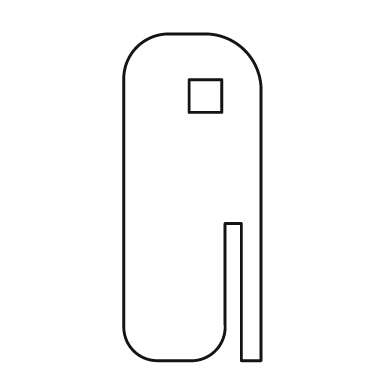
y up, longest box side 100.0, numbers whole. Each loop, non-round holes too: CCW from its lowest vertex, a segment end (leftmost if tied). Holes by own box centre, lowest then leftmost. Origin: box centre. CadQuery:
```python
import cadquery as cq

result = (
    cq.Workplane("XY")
    .moveTo(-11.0, -50.0)
    .lineTo(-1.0, -50.0)
    .threePointArc((7.0, -47.0), (10.0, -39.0))
    .lineTo(10.0, -8.0)
    .lineTo(15.0, -8.0)
    .lineTo(15.0, -50.0)
    .lineTo(21.0, -50.0)
    .lineTo(21.0, 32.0)
    .threePointArc((16.0, 45.0), (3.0, 50.0))
    .lineTo(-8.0, 50.0)
    .threePointArc((-17.0, 46.0), (-21.0, 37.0))
    .lineTo(-21.0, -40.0)
    .threePointArc((-18.0, -47.0), (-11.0, -50.0))
    .close()
    .moveTo(-1.0, 26.0)
    .lineTo(9.0, 26.0)
    .lineTo(9.0, 36.0)
    .lineTo(-1.0, 36.0)
    .close()
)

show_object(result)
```